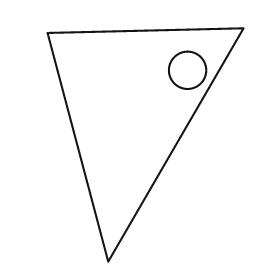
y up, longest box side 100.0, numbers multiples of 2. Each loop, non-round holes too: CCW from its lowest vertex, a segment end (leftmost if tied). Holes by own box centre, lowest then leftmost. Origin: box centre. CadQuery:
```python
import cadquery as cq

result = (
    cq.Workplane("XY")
    .moveTo(-16.0, -50.0)
    .lineTo(42.0, 50.0)
    .lineTo(-42.0, 48.0)
    .close()
    .moveTo(18.0, 32.0)
    .circle(8.0)
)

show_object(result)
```